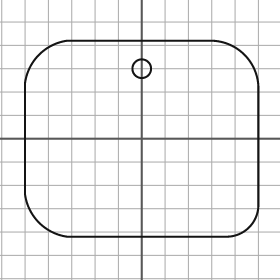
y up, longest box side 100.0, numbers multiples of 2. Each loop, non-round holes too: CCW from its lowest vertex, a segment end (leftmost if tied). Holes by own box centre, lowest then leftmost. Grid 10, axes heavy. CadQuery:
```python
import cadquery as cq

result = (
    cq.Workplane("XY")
    .moveTo(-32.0, -42.0)
    .lineTo(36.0, -42.0)
    .threePointArc((46.0, -38.0), (50.0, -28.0))
    .lineTo(50.0, 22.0)
    .threePointArc((44.0, 36.0), (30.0, 42.0))
    .lineTo(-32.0, 42.0)
    .threePointArc((-44.0, 36.0), (-50.0, 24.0))
    .lineTo(-50.0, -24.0)
    .threePointArc((-44.0, -36.0), (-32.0, -42.0))
    .close()
    .moveTo(0.0, 30.0)
    .circle(4.0)
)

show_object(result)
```